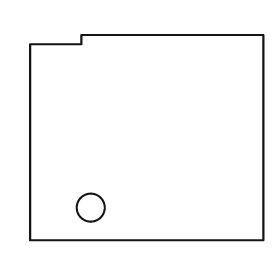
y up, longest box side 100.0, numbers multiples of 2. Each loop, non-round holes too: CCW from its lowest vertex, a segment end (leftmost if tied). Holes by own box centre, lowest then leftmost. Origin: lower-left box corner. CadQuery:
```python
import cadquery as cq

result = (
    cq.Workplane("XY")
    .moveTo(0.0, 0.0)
    .lineTo(100.0, 0.0)
    .lineTo(100.0, 88.0)
    .lineTo(22.0, 88.0)
    .lineTo(22.0, 84.0)
    .lineTo(0.0, 84.0)
    .close()
    .moveTo(26.0, 14.0)
    .circle(6.0)
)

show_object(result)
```